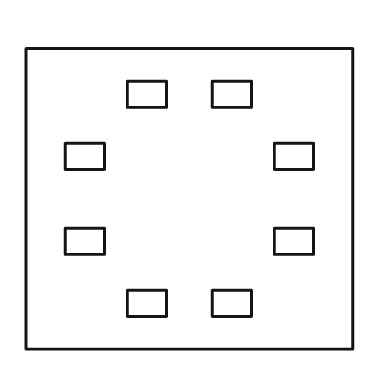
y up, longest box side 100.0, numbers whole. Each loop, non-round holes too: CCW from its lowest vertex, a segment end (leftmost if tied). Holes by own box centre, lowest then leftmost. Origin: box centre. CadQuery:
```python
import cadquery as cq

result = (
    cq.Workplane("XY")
    .moveTo(-50.0, -46.0)
    .lineTo(50.0, -46.0)
    .lineTo(50.0, 46.0)
    .lineTo(-50.0, 46.0)
    .close()
    .moveTo(-19.0, -36.0)
    .lineTo(-7.0, -36.0)
    .lineTo(-7.0, -28.0)
    .lineTo(-19.0, -28.0)
    .close()
    .moveTo(7.0, -36.0)
    .lineTo(19.0, -36.0)
    .lineTo(19.0, -28.0)
    .lineTo(7.0, -28.0)
    .close()
    .moveTo(-38.0, -17.0)
    .lineTo(-26.0, -17.0)
    .lineTo(-26.0, -9.0)
    .lineTo(-38.0, -9.0)
    .close()
    .moveTo(26.0, -17.0)
    .lineTo(38.0, -17.0)
    .lineTo(38.0, -9.0)
    .lineTo(26.0, -9.0)
    .close()
    .moveTo(-38.0, 9.0)
    .lineTo(-26.0, 9.0)
    .lineTo(-26.0, 17.0)
    .lineTo(-38.0, 17.0)
    .close()
    .moveTo(26.0, 9.0)
    .lineTo(38.0, 9.0)
    .lineTo(38.0, 17.0)
    .lineTo(26.0, 17.0)
    .close()
    .moveTo(-19.0, 28.0)
    .lineTo(-7.0, 28.0)
    .lineTo(-7.0, 36.0)
    .lineTo(-19.0, 36.0)
    .close()
    .moveTo(7.0, 28.0)
    .lineTo(19.0, 28.0)
    .lineTo(19.0, 36.0)
    .lineTo(7.0, 36.0)
    .close()
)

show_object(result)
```